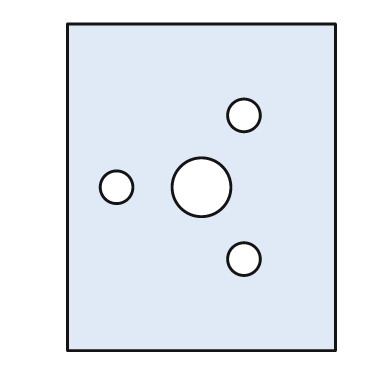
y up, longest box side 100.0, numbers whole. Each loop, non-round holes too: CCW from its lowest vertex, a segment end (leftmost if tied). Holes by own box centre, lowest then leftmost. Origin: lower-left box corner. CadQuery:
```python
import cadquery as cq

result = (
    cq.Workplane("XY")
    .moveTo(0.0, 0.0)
    .lineTo(82.0, 0.0)
    .lineTo(82.0, 100.0)
    .lineTo(0.0, 100.0)
    .close()
    .moveTo(54.0, 28.0)
    .circle(5.0)
    .moveTo(15.0, 50.0)
    .circle(5.0)
    .moveTo(41.0, 50.0)
    .circle(9.0)
    .moveTo(54.0, 72.0)
    .circle(5.0)
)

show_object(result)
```